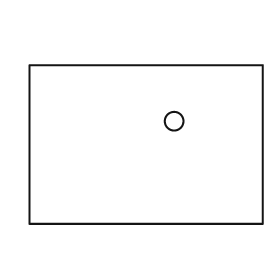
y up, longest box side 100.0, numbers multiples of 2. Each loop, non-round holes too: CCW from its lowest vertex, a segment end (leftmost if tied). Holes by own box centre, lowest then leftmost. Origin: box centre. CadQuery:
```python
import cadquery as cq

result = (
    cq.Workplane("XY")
    .moveTo(-50.0, -34.0)
    .lineTo(50.0, -34.0)
    .lineTo(50.0, 34.0)
    .lineTo(-50.0, 34.0)
    .close()
    .moveTo(12.0, 10.0)
    .circle(4.0)
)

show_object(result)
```